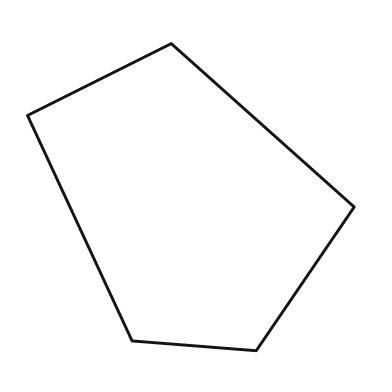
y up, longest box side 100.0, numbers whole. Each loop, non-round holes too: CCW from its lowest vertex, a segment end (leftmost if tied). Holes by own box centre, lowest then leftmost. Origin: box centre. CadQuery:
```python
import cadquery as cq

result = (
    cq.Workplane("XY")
    .moveTo(20.0, -47.0)
    .lineTo(50.0, -3.0)
    .lineTo(-6.0, 47.0)
    .lineTo(-50.0, 25.0)
    .lineTo(-18.0, -44.0)
    .close()
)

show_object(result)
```